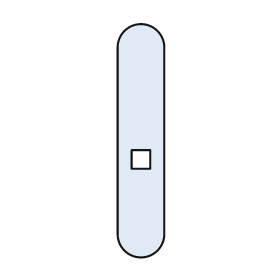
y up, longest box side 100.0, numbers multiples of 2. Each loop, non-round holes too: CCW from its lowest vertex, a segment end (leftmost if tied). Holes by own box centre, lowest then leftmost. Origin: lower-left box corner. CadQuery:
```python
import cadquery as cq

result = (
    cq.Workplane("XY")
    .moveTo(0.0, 10.0)
    .threePointArc((10.0, 0.0), (20.0, 10.0))
    .lineTo(20.0, 90.0)
    .threePointArc((10.0, 100.0), (0.0, 90.0))
    .close()
    .moveTo(6.0, 38.0)
    .lineTo(14.0, 38.0)
    .lineTo(14.0, 46.0)
    .lineTo(6.0, 46.0)
    .close()
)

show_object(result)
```